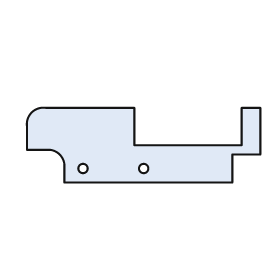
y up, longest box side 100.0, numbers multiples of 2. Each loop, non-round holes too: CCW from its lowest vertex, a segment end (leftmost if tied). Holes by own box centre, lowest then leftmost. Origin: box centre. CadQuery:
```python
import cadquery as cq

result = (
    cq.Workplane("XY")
    .moveTo(-34.0, -16.0)
    .lineTo(38.0, -16.0)
    .lineTo(38.0, -4.0)
    .lineTo(50.0, -4.0)
    .lineTo(50.0, 16.0)
    .lineTo(42.0, 16.0)
    .lineTo(42.0, 0.0)
    .lineTo(-4.0, 0.0)
    .lineTo(-4.0, 16.0)
    .lineTo(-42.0, 16.0)
    .threePointArc((-48.0, 14.0), (-50.0, 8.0))
    .lineTo(-50.0, -2.0)
    .lineTo(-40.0, -2.0)
    .threePointArc((-36.0, -4.0), (-34.0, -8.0))
    .close()
    .moveTo(-26.0, -10.0)
    .circle(2.0)
    .moveTo(0.0, -10.0)
    .circle(2.0)
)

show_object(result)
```